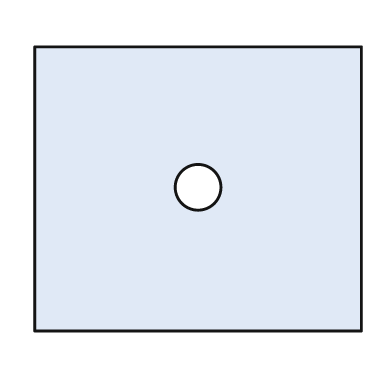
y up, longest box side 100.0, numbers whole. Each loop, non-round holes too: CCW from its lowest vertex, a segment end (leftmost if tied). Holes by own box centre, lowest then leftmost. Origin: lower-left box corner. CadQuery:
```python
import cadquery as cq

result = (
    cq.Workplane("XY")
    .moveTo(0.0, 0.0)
    .lineTo(100.0, 0.0)
    .lineTo(100.0, 87.0)
    .lineTo(0.0, 87.0)
    .close()
    .moveTo(50.0, 44.0)
    .circle(7.0)
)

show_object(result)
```